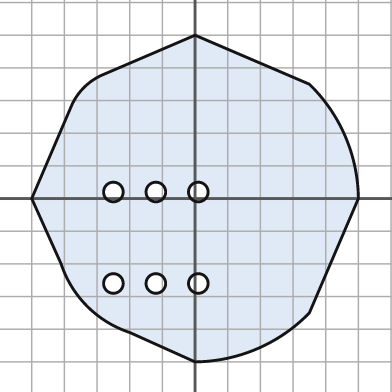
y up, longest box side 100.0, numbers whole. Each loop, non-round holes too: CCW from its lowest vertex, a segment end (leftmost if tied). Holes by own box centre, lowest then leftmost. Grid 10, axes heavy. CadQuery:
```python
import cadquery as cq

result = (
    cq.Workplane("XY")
    .moveTo(0.0, -50.0)
    .threePointArc((19.0, -46.0), (35.0, -35.0))
    .lineTo(50.0, 0.0)
    .threePointArc((46.0, 19.0), (35.0, 35.0))
    .lineTo(0.0, 50.0)
    .lineTo(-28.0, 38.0)
    .threePointArc((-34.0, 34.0), (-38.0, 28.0))
    .lineTo(-50.0, 0.0)
    .lineTo(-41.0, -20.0)
    .threePointArc((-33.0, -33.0), (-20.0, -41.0))
    .close()
    .moveTo(-25.0, -26.0)
    .circle(3.0)
    .moveTo(-12.0, -26.0)
    .circle(3.0)
    .moveTo(1.0, -26.0)
    .circle(3.0)
    .moveTo(-25.0, 2.0)
    .circle(3.0)
    .moveTo(-12.0, 2.0)
    .circle(3.0)
    .moveTo(1.0, 2.0)
    .circle(3.0)
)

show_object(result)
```